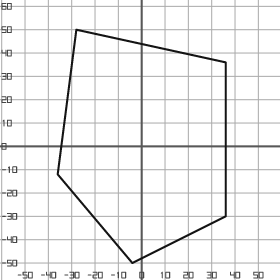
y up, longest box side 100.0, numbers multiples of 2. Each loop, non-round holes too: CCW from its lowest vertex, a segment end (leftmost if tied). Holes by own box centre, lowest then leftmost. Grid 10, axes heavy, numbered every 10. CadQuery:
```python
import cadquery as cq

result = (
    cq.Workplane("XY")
    .moveTo(-4.0, -50.0)
    .lineTo(36.0, -30.0)
    .lineTo(36.0, 36.0)
    .lineTo(-28.0, 50.0)
    .lineTo(-36.0, -12.0)
    .close()
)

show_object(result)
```